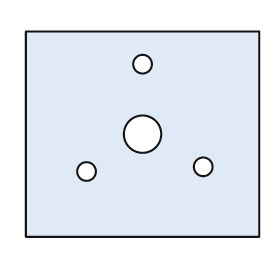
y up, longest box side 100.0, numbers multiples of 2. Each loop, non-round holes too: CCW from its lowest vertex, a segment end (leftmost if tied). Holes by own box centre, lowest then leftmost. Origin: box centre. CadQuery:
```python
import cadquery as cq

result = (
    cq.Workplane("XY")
    .moveTo(-50.0, -44.0)
    .lineTo(50.0, -44.0)
    .lineTo(50.0, 44.0)
    .lineTo(-50.0, 44.0)
    .close()
    .moveTo(-24.0, -16.0)
    .circle(4.0)
    .moveTo(26.0, -14.0)
    .circle(4.0)
    .moveTo(0.0, 0.0)
    .circle(8.0)
    .moveTo(0.0, 30.0)
    .circle(4.0)
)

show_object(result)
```